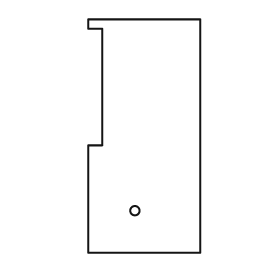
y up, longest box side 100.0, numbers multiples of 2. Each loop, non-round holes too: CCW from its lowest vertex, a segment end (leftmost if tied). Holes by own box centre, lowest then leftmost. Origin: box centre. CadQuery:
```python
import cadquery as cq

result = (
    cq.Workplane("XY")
    .moveTo(-24.0, -50.0)
    .lineTo(24.0, -50.0)
    .lineTo(24.0, 50.0)
    .lineTo(-24.0, 50.0)
    .lineTo(-24.0, 46.0)
    .lineTo(-18.0, 46.0)
    .lineTo(-18.0, -4.0)
    .lineTo(-24.0, -4.0)
    .close()
    .moveTo(-4.0, -32.0)
    .circle(2.0)
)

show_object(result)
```